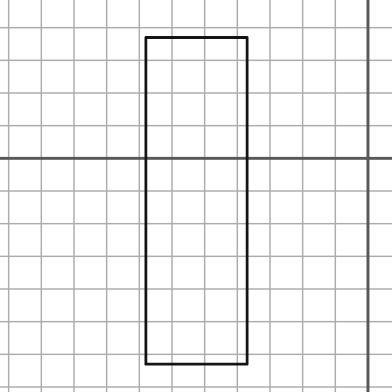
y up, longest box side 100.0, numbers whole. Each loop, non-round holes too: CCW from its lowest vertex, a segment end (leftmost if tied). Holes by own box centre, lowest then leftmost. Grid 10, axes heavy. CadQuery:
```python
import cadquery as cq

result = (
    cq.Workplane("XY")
    .moveTo(-68.0, -63.0)
    .lineTo(-37.0, -63.0)
    .lineTo(-37.0, 37.0)
    .lineTo(-68.0, 37.0)
    .close()
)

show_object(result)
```